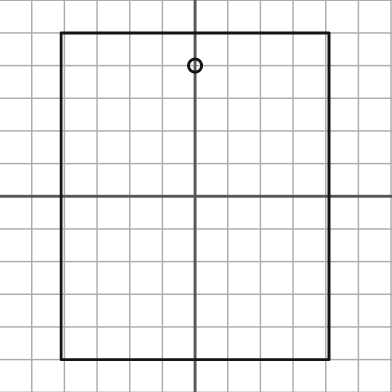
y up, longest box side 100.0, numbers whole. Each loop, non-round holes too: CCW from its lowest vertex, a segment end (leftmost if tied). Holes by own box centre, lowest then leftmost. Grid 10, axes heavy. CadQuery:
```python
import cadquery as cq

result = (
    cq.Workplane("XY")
    .moveTo(-41.0, -50.0)
    .lineTo(41.0, -50.0)
    .lineTo(41.0, 50.0)
    .lineTo(-41.0, 50.0)
    .close()
    .moveTo(0.0, 40.0)
    .circle(2.0)
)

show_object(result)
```